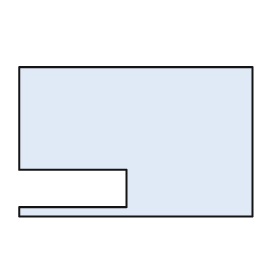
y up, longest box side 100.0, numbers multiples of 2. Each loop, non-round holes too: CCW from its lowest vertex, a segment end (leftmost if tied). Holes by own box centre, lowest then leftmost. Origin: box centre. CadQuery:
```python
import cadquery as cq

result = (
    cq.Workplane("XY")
    .moveTo(-50.0, -32.0)
    .lineTo(50.0, -32.0)
    .lineTo(50.0, 32.0)
    .lineTo(-50.0, 32.0)
    .lineTo(-50.0, -12.0)
    .lineTo(-4.0, -12.0)
    .lineTo(-4.0, -28.0)
    .lineTo(-50.0, -28.0)
    .close()
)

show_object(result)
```